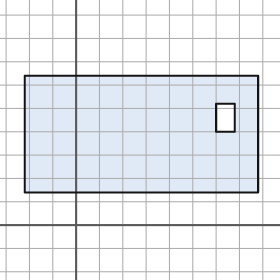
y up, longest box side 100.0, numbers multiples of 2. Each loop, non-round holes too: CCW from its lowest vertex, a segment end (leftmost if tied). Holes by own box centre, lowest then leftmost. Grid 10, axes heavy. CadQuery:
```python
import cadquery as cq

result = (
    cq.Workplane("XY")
    .moveTo(-22.0, 14.0)
    .lineTo(78.0, 14.0)
    .lineTo(78.0, 64.0)
    .lineTo(-22.0, 64.0)
    .close()
    .moveTo(60.0, 40.0)
    .lineTo(68.0, 40.0)
    .lineTo(68.0, 52.0)
    .lineTo(60.0, 52.0)
    .close()
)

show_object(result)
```